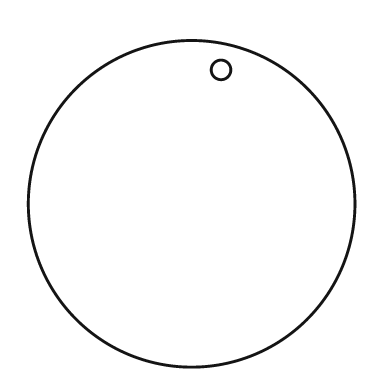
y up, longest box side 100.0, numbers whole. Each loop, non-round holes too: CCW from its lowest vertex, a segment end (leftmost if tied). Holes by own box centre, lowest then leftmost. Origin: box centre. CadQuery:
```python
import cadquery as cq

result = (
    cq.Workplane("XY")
    .moveTo(0.0, 0.0)
    .circle(50.0)
    .moveTo(9.0, 41.0)
    .circle(3.0)
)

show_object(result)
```